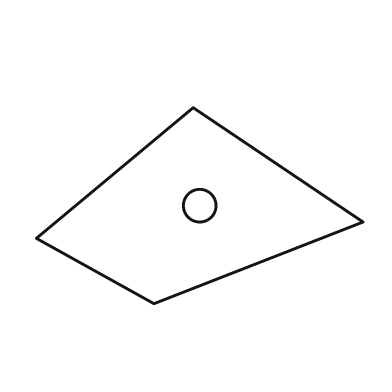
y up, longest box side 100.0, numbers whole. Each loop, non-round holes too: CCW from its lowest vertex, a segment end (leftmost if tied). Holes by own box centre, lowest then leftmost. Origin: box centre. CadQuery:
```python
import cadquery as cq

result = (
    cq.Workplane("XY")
    .moveTo(-14.0, -30.0)
    .lineTo(50.0, -5.0)
    .lineTo(-2.0, 30.0)
    .lineTo(-50.0, -10.0)
    .close()
    .moveTo(0.0, 0.0)
    .circle(5.0)
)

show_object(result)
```